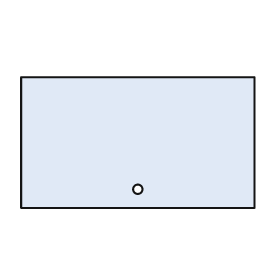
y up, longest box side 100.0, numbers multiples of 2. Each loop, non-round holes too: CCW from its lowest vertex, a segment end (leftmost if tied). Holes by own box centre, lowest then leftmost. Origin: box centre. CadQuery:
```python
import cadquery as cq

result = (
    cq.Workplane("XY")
    .moveTo(-50.0, -28.0)
    .lineTo(50.0, -28.0)
    .lineTo(50.0, 28.0)
    .lineTo(-50.0, 28.0)
    .close()
    .moveTo(0.0, -20.0)
    .circle(2.0)
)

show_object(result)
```